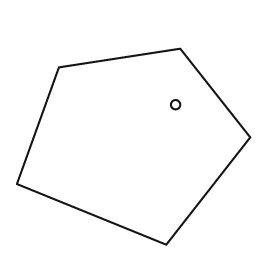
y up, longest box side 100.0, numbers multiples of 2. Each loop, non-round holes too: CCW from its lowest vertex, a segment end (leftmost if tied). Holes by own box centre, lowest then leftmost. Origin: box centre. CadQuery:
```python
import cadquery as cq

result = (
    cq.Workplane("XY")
    .moveTo(14.0, -42.0)
    .lineTo(50.0, 4.0)
    .lineTo(20.0, 42.0)
    .lineTo(-32.0, 34.0)
    .lineTo(-50.0, -16.0)
    .close()
    .moveTo(18.0, 18.0)
    .circle(2.0)
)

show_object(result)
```